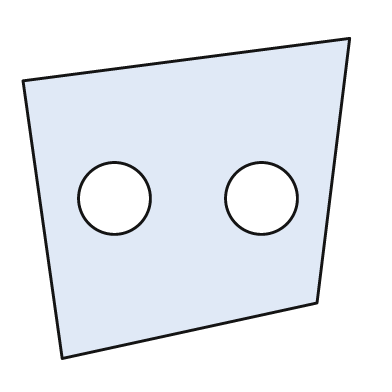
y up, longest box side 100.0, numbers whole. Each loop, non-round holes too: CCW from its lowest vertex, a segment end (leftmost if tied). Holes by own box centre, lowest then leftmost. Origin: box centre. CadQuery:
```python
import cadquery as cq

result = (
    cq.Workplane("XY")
    .moveTo(-38.0, -49.0)
    .lineTo(40.0, -32.0)
    .lineTo(50.0, 49.0)
    .lineTo(-50.0, 36.0)
    .close()
    .moveTo(-22.0, 0.0)
    .circle(11.0)
    .moveTo(23.0, 0.0)
    .circle(11.0)
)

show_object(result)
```